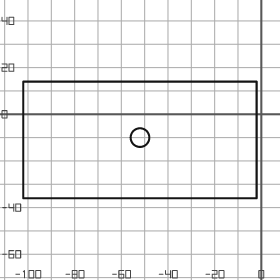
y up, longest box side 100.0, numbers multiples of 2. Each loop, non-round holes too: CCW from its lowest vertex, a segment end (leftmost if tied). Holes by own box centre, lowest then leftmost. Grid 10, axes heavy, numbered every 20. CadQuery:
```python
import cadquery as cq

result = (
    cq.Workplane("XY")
    .moveTo(-102.0, -36.0)
    .lineTo(-2.0, -36.0)
    .lineTo(-2.0, 14.0)
    .lineTo(-102.0, 14.0)
    .close()
    .moveTo(-52.0, -10.0)
    .circle(4.0)
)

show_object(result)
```